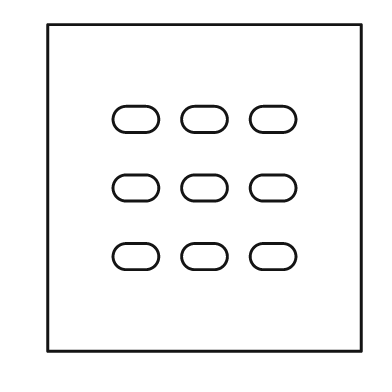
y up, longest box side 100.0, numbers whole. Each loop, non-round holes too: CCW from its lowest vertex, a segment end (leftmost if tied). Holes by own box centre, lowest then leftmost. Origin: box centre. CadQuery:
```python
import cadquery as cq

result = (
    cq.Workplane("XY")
    .moveTo(-48.0, -50.0)
    .lineTo(48.0, -50.0)
    .lineTo(48.0, 50.0)
    .lineTo(-48.0, 50.0)
    .close()
    .moveTo(-24.0, -25.0)
    .lineTo(-18.0, -25.0)
    .threePointArc((-14.0, -21.0), (-18.0, -17.0))
    .lineTo(-24.0, -17.0)
    .threePointArc((-28.0, -21.0), (-24.0, -25.0))
    .close()
    .moveTo(-3.0, -25.0)
    .lineTo(3.0, -25.0)
    .threePointArc((7.0, -21.0), (3.0, -17.0))
    .lineTo(-3.0, -17.0)
    .threePointArc((-7.0, -21.0), (-3.0, -25.0))
    .close()
    .moveTo(18.0, -25.0)
    .lineTo(24.0, -25.0)
    .threePointArc((28.0, -21.0), (24.0, -17.0))
    .lineTo(18.0, -17.0)
    .threePointArc((14.0, -21.0), (18.0, -25.0))
    .close()
    .moveTo(-24.0, -4.0)
    .lineTo(-18.0, -4.0)
    .threePointArc((-14.0, 0.0), (-18.0, 4.0))
    .lineTo(-24.0, 4.0)
    .threePointArc((-28.0, 0.0), (-24.0, -4.0))
    .close()
    .moveTo(-3.0, -4.0)
    .lineTo(3.0, -4.0)
    .threePointArc((7.0, 0.0), (3.0, 4.0))
    .lineTo(-3.0, 4.0)
    .threePointArc((-7.0, 0.0), (-3.0, -4.0))
    .close()
    .moveTo(18.0, -4.0)
    .lineTo(24.0, -4.0)
    .threePointArc((28.0, 0.0), (24.0, 4.0))
    .lineTo(18.0, 4.0)
    .threePointArc((14.0, 0.0), (18.0, -4.0))
    .close()
    .moveTo(-24.0, 17.0)
    .lineTo(-18.0, 17.0)
    .threePointArc((-14.0, 21.0), (-18.0, 25.0))
    .lineTo(-24.0, 25.0)
    .threePointArc((-28.0, 21.0), (-24.0, 17.0))
    .close()
    .moveTo(-3.0, 17.0)
    .lineTo(3.0, 17.0)
    .threePointArc((7.0, 21.0), (3.0, 25.0))
    .lineTo(-3.0, 25.0)
    .threePointArc((-7.0, 21.0), (-3.0, 17.0))
    .close()
    .moveTo(18.0, 17.0)
    .lineTo(24.0, 17.0)
    .threePointArc((28.0, 21.0), (24.0, 25.0))
    .lineTo(18.0, 25.0)
    .threePointArc((14.0, 21.0), (18.0, 17.0))
    .close()
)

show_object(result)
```